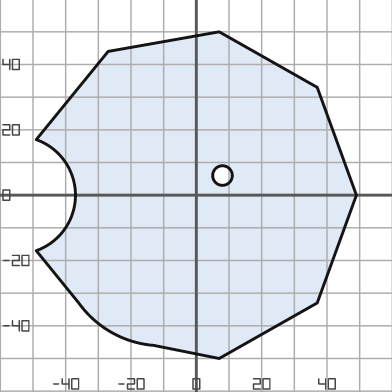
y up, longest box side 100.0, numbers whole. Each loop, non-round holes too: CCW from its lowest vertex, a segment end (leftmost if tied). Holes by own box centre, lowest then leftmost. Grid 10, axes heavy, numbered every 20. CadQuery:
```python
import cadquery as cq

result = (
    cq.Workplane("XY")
    .moveTo(7.0, -50.0)
    .lineTo(37.0, -33.0)
    .lineTo(49.0, 0.0)
    .lineTo(37.0, 33.0)
    .lineTo(7.0, 50.0)
    .lineTo(-27.0, 44.0)
    .lineTo(-49.0, 17.0)
    .threePointArc((-37.0, 0.0), (-49.0, -17.0))
    .lineTo(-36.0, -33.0)
    .threePointArc((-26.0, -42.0), (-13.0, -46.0))
    .close()
    .moveTo(8.0, 6.0)
    .circle(3.0)
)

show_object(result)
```